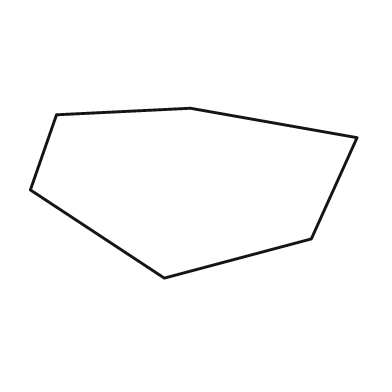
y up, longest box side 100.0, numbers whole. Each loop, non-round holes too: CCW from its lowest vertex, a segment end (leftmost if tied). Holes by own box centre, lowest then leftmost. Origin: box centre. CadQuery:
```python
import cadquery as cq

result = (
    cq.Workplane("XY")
    .moveTo(-9.0, -26.0)
    .lineTo(36.0, -14.0)
    .lineTo(50.0, 17.0)
    .lineTo(-1.0, 26.0)
    .lineTo(-42.0, 24.0)
    .lineTo(-50.0, 1.0)
    .close()
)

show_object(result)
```